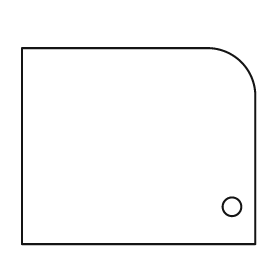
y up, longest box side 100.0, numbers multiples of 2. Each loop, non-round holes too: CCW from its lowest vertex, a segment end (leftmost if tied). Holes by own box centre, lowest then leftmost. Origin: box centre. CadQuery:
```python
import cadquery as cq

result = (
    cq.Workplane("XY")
    .moveTo(-50.0, -42.0)
    .lineTo(50.0, -42.0)
    .lineTo(50.0, 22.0)
    .threePointArc((44.0, 36.0), (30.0, 42.0))
    .lineTo(-50.0, 42.0)
    .close()
    .moveTo(40.0, -26.0)
    .circle(4.0)
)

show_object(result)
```